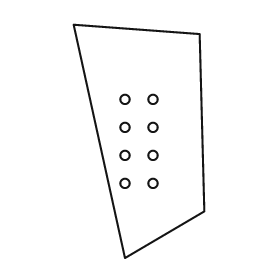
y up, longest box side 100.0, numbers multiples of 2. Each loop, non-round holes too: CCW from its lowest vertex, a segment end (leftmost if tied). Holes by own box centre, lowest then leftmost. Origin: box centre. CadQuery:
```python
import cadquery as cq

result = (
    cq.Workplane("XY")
    .moveTo(-6.0, -50.0)
    .lineTo(28.0, -30.0)
    .lineTo(26.0, 46.0)
    .lineTo(-28.0, 50.0)
    .close()
    .moveTo(-6.0, -18.0)
    .circle(2.0)
    .moveTo(6.0, -18.0)
    .circle(2.0)
    .moveTo(-6.0, -6.0)
    .circle(2.0)
    .moveTo(6.0, -6.0)
    .circle(2.0)
    .moveTo(-6.0, 6.0)
    .circle(2.0)
    .moveTo(6.0, 6.0)
    .circle(2.0)
    .moveTo(-6.0, 18.0)
    .circle(2.0)
    .moveTo(6.0, 18.0)
    .circle(2.0)
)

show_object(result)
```